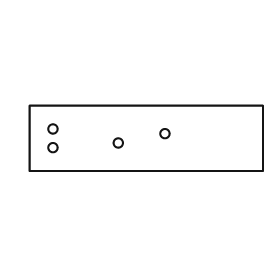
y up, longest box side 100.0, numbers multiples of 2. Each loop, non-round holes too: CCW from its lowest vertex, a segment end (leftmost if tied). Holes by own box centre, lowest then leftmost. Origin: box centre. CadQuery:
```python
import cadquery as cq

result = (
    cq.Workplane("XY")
    .moveTo(-50.0, -14.0)
    .lineTo(50.0, -14.0)
    .lineTo(50.0, 14.0)
    .lineTo(-50.0, 14.0)
    .close()
    .moveTo(-40.0, -4.0)
    .circle(2.0)
    .moveTo(-12.0, -2.0)
    .circle(2.0)
    .moveTo(8.0, 2.0)
    .circle(2.0)
    .moveTo(-40.0, 4.0)
    .circle(2.0)
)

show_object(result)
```